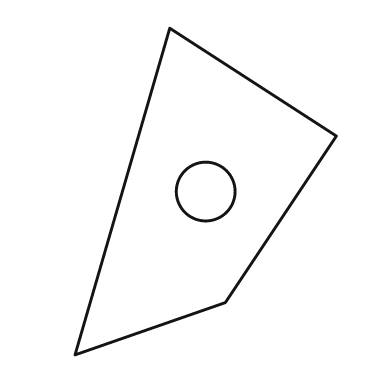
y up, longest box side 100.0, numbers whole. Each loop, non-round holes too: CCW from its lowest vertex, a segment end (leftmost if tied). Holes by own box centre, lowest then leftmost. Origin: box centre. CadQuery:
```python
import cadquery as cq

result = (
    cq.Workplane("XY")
    .moveTo(-40.0, -50.0)
    .lineTo(6.0, -34.0)
    .lineTo(40.0, 17.0)
    .lineTo(-11.0, 50.0)
    .close()
    .moveTo(0.0, 0.0)
    .circle(9.0)
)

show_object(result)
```